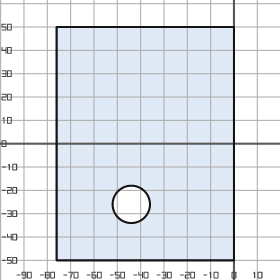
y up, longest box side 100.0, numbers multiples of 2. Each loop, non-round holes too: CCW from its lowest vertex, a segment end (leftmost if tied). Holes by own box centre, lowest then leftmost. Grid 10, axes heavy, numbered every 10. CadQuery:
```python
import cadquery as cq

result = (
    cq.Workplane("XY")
    .moveTo(-76.0, -50.0)
    .lineTo(0.0, -50.0)
    .lineTo(0.0, 50.0)
    .lineTo(-76.0, 50.0)
    .close()
    .moveTo(-44.0, -26.0)
    .circle(8.0)
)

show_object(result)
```